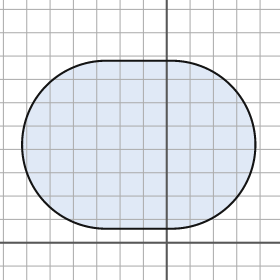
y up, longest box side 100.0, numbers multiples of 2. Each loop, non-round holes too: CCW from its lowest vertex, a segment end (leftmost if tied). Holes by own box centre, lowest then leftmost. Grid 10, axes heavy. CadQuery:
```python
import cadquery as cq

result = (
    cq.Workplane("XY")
    .moveTo(-26.0, 6.0)
    .lineTo(2.0, 6.0)
    .threePointArc((38.0, 42.0), (2.0, 78.0))
    .lineTo(-26.0, 78.0)
    .threePointArc((-62.0, 42.0), (-26.0, 6.0))
    .close()
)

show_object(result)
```